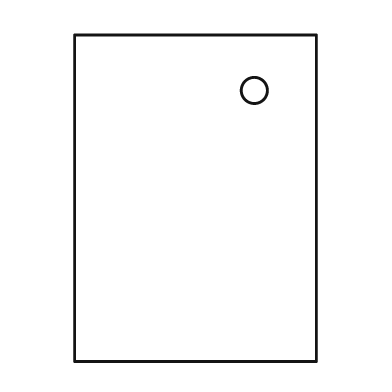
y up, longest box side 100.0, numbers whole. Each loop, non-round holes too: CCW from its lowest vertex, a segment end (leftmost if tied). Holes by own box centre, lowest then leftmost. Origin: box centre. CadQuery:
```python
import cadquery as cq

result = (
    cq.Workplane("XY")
    .moveTo(-37.0, -50.0)
    .lineTo(37.0, -50.0)
    .lineTo(37.0, 50.0)
    .lineTo(-37.0, 50.0)
    .close()
    .moveTo(18.0, 33.0)
    .circle(4.0)
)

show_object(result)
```